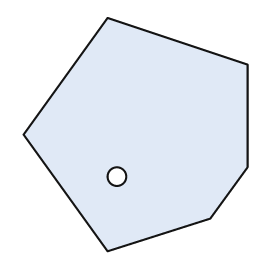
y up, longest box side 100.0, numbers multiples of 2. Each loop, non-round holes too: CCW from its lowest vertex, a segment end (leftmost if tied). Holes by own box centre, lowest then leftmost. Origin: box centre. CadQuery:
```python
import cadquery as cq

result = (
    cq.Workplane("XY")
    .moveTo(-12.0, -50.0)
    .lineTo(32.0, -36.0)
    .lineTo(48.0, -14.0)
    .lineTo(48.0, 30.0)
    .lineTo(-12.0, 50.0)
    .lineTo(-48.0, 0.0)
    .close()
    .moveTo(-8.0, -18.0)
    .circle(4.0)
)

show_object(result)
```